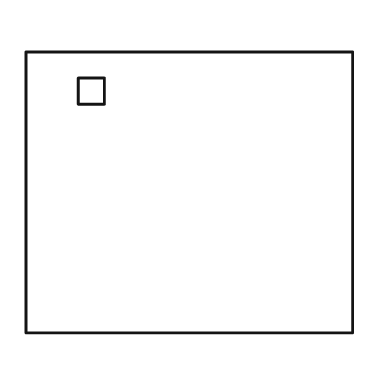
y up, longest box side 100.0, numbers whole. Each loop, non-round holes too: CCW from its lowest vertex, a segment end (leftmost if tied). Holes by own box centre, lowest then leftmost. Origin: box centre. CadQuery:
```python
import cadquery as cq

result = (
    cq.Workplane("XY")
    .moveTo(-50.0, -43.0)
    .lineTo(50.0, -43.0)
    .lineTo(50.0, 43.0)
    .lineTo(-50.0, 43.0)
    .close()
    .moveTo(-34.0, 27.0)
    .lineTo(-26.0, 27.0)
    .lineTo(-26.0, 35.0)
    .lineTo(-34.0, 35.0)
    .close()
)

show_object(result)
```